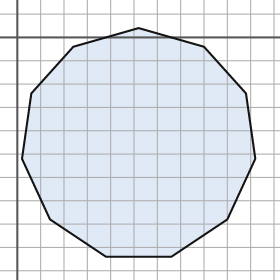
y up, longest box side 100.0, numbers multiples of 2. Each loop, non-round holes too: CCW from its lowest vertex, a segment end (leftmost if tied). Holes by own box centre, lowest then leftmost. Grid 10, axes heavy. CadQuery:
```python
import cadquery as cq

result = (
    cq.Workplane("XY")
    .moveTo(38.0, -94.0)
    .lineTo(66.0, -94.0)
    .lineTo(90.0, -78.0)
    .lineTo(102.0, -52.0)
    .lineTo(98.0, -24.0)
    .lineTo(80.0, -4.0)
    .lineTo(52.0, 4.0)
    .lineTo(24.0, -4.0)
    .lineTo(6.0, -24.0)
    .lineTo(2.0, -52.0)
    .lineTo(14.0, -78.0)
    .close()
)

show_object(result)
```